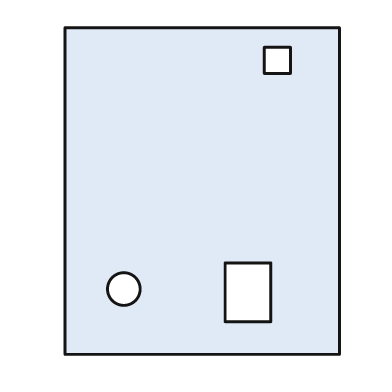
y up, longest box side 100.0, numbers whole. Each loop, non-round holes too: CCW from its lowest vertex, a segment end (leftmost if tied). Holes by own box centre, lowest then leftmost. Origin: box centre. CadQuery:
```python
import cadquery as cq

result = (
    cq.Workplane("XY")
    .moveTo(-42.0, -50.0)
    .lineTo(42.0, -50.0)
    .lineTo(42.0, 50.0)
    .lineTo(-42.0, 50.0)
    .close()
    .moveTo(7.0, -40.0)
    .lineTo(21.0, -40.0)
    .lineTo(21.0, -22.0)
    .lineTo(7.0, -22.0)
    .close()
    .moveTo(-24.0, -30.0)
    .circle(5.0)
    .moveTo(19.0, 36.0)
    .lineTo(27.0, 36.0)
    .lineTo(27.0, 44.0)
    .lineTo(19.0, 44.0)
    .close()
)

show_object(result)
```